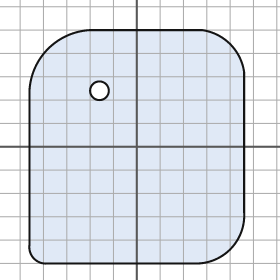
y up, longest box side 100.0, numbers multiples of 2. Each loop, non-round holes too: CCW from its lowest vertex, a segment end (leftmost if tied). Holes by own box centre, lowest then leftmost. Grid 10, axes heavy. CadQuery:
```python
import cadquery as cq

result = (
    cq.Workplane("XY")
    .moveTo(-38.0, -50.0)
    .lineTo(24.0, -50.0)
    .threePointArc((40.0, -44.0), (46.0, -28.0))
    .lineTo(46.0, 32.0)
    .threePointArc((40.0, 44.0), (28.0, 50.0))
    .lineTo(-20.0, 50.0)
    .threePointArc((-38.0, 42.0), (-46.0, 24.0))
    .lineTo(-46.0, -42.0)
    .threePointArc((-44.0, -48.0), (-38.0, -50.0))
    .close()
    .moveTo(-16.0, 24.0)
    .circle(4.0)
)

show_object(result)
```